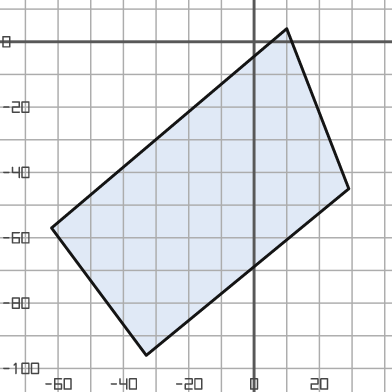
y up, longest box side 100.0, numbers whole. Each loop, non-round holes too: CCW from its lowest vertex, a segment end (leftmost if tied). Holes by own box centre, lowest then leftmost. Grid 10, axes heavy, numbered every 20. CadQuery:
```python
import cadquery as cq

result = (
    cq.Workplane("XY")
    .moveTo(-33.0, -96.0)
    .lineTo(29.0, -45.0)
    .lineTo(10.0, 4.0)
    .lineTo(-62.0, -57.0)
    .close()
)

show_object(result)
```